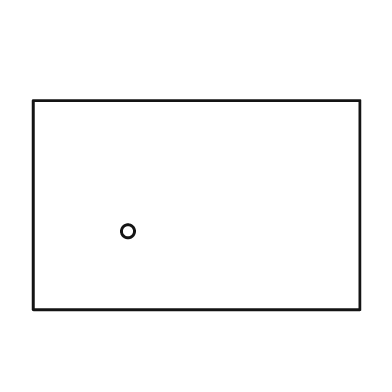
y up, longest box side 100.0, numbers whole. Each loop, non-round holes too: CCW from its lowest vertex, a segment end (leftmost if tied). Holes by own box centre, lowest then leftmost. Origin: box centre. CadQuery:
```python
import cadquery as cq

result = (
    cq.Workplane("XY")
    .moveTo(-50.0, -32.0)
    .lineTo(50.0, -32.0)
    .lineTo(50.0, 32.0)
    .lineTo(-50.0, 32.0)
    .close()
    .moveTo(-21.0, -8.0)
    .circle(2.0)
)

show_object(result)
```